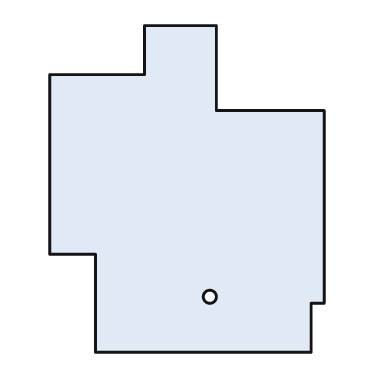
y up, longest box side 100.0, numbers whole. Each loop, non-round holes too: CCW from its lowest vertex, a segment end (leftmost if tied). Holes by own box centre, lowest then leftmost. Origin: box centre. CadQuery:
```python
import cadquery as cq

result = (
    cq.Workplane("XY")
    .moveTo(-28.0, -50.0)
    .lineTo(38.0, -50.0)
    .lineTo(38.0, -35.0)
    .lineTo(42.0, -35.0)
    .lineTo(42.0, 24.0)
    .lineTo(9.0, 24.0)
    .lineTo(9.0, 50.0)
    .lineTo(-13.0, 50.0)
    .lineTo(-13.0, 35.0)
    .lineTo(-42.0, 35.0)
    .lineTo(-42.0, -20.0)
    .lineTo(-28.0, -20.0)
    .close()
    .moveTo(7.0, -33.0)
    .circle(2.0)
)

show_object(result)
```